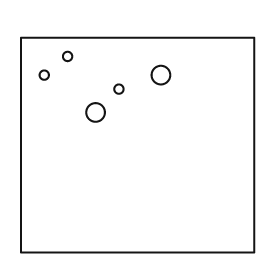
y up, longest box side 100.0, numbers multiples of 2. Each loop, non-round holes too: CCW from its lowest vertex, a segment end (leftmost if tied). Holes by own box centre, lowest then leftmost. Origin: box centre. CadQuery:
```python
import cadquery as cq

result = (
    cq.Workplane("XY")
    .moveTo(-50.0, -46.0)
    .lineTo(50.0, -46.0)
    .lineTo(50.0, 46.0)
    .lineTo(-50.0, 46.0)
    .close()
    .moveTo(-18.0, 14.0)
    .circle(4.0)
    .moveTo(-8.0, 24.0)
    .circle(2.0)
    .moveTo(-40.0, 30.0)
    .circle(2.0)
    .moveTo(10.0, 30.0)
    .circle(4.0)
    .moveTo(-30.0, 38.0)
    .circle(2.0)
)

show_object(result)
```